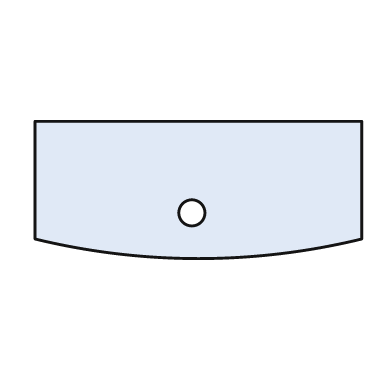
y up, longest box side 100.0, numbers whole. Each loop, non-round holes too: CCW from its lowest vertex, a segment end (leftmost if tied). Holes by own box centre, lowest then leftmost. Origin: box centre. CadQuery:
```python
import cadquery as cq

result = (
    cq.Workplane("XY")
    .moveTo(-50.0, -15.0)
    .threePointArc((0.0, -21.0), (50.0, -15.0))
    .lineTo(50.0, 21.0)
    .lineTo(-50.0, 21.0)
    .close()
    .moveTo(-2.0, -7.0)
    .circle(4.0)
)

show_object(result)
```